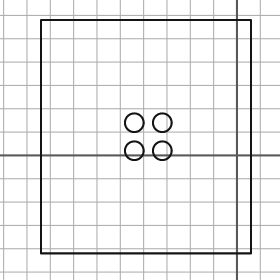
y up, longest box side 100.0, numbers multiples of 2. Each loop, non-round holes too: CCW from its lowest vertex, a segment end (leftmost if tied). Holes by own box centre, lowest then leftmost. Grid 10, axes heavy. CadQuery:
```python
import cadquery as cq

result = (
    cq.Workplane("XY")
    .moveTo(-84.0, -42.0)
    .lineTo(6.0, -42.0)
    .lineTo(6.0, 58.0)
    .lineTo(-84.0, 58.0)
    .close()
    .moveTo(-44.0, 2.0)
    .circle(4.0)
    .moveTo(-32.0, 2.0)
    .circle(4.0)
    .moveTo(-44.0, 14.0)
    .circle(4.0)
    .moveTo(-32.0, 14.0)
    .circle(4.0)
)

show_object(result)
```